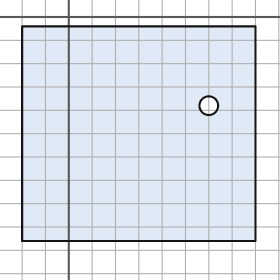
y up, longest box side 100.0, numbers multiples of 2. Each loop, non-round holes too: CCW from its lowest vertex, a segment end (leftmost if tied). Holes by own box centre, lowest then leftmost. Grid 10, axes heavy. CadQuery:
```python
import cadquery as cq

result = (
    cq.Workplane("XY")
    .moveTo(-20.0, -96.0)
    .lineTo(80.0, -96.0)
    .lineTo(80.0, -4.0)
    .lineTo(-20.0, -4.0)
    .close()
    .moveTo(60.0, -38.0)
    .circle(4.0)
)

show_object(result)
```